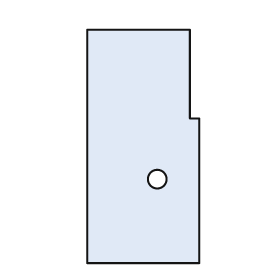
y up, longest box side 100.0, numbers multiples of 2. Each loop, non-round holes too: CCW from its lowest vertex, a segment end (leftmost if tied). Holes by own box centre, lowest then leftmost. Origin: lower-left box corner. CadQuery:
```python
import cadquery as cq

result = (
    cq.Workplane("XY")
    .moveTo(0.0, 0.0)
    .lineTo(48.0, 0.0)
    .lineTo(48.0, 62.0)
    .lineTo(44.0, 62.0)
    .lineTo(44.0, 100.0)
    .lineTo(0.0, 100.0)
    .close()
    .moveTo(30.0, 36.0)
    .circle(4.0)
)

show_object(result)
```